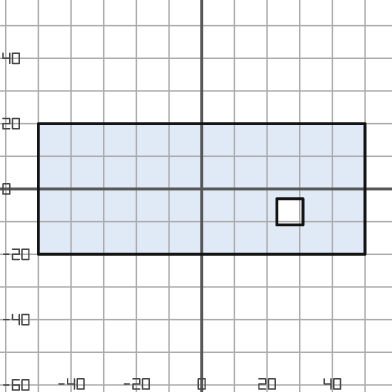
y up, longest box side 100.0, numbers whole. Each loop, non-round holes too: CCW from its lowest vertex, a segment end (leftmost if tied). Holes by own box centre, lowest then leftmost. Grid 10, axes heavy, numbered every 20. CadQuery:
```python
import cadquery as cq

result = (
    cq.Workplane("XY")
    .moveTo(-50.0, -20.0)
    .lineTo(50.0, -20.0)
    .lineTo(50.0, 20.0)
    .lineTo(-50.0, 20.0)
    .close()
    .moveTo(23.0, -11.0)
    .lineTo(31.0, -11.0)
    .lineTo(31.0, -3.0)
    .lineTo(23.0, -3.0)
    .close()
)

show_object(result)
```